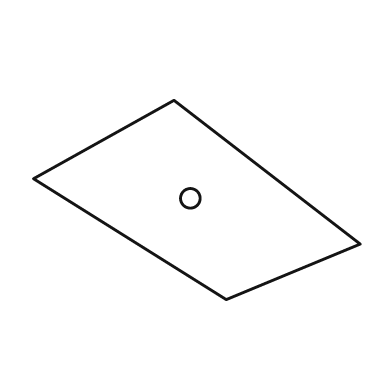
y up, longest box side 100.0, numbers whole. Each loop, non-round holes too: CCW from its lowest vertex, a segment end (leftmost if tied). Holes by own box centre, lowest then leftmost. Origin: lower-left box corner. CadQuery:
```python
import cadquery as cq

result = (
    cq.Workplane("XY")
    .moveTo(59.0, 0.0)
    .lineTo(100.0, 17.0)
    .lineTo(43.0, 61.0)
    .lineTo(0.0, 37.0)
    .close()
    .moveTo(48.0, 31.0)
    .circle(3.0)
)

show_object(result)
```